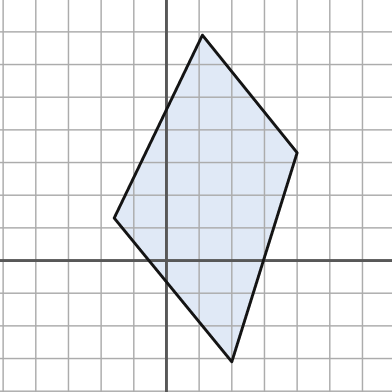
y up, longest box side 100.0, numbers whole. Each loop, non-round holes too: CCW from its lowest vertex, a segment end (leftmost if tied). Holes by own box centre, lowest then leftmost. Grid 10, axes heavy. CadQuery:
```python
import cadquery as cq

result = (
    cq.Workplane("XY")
    .moveTo(20.0, -31.0)
    .lineTo(40.0, 33.0)
    .lineTo(11.0, 69.0)
    .lineTo(-16.0, 13.0)
    .close()
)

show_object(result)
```